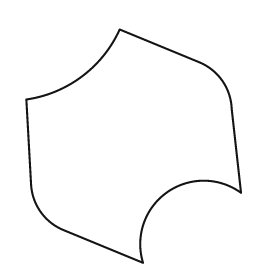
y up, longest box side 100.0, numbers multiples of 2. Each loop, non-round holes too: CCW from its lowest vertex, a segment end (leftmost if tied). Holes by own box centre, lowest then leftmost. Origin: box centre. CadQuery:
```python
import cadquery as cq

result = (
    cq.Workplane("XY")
    .moveTo(4.0, -50.0)
    .threePointArc((14.0, -20.0), (46.0, -20.0))
    .lineTo(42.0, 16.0)
    .threePointArc((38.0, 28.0), (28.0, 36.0))
    .lineTo(-6.0, 50.0)
    .threePointArc((-22.0, 30.0), (-46.0, 20.0))
    .lineTo(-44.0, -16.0)
    .threePointArc((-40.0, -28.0), (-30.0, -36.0))
    .close()
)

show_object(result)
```